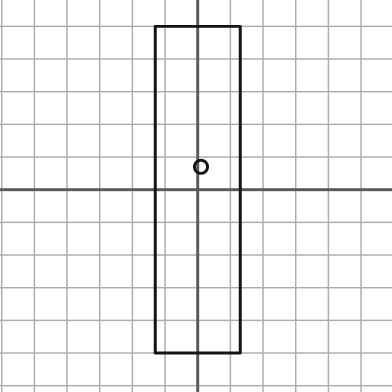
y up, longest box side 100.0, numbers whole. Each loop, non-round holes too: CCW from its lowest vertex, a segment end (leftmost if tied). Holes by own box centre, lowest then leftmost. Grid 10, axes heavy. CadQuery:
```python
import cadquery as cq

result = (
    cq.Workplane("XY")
    .moveTo(-13.0, -50.0)
    .lineTo(13.0, -50.0)
    .lineTo(13.0, 50.0)
    .lineTo(-13.0, 50.0)
    .close()
    .moveTo(1.0, 7.0)
    .circle(2.0)
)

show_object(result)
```